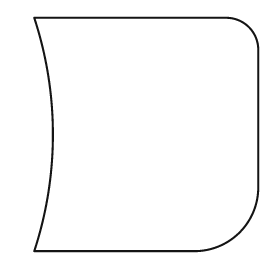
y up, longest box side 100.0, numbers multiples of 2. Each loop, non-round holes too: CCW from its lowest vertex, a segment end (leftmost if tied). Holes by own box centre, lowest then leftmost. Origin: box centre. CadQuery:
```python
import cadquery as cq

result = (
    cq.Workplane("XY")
    .moveTo(-48.0, -50.0)
    .lineTo(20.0, -50.0)
    .threePointArc((40.0, -42.0), (48.0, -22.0))
    .lineTo(48.0, 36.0)
    .threePointArc((44.0, 46.0), (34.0, 50.0))
    .lineTo(-48.0, 50.0)
    .threePointArc((-40.0, 0.0), (-48.0, -50.0))
    .close()
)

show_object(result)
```